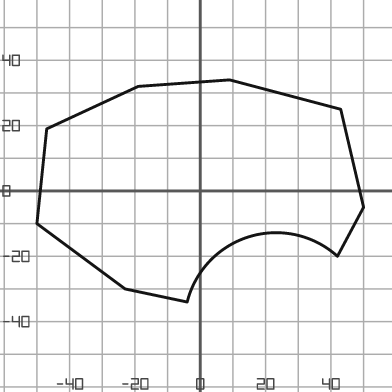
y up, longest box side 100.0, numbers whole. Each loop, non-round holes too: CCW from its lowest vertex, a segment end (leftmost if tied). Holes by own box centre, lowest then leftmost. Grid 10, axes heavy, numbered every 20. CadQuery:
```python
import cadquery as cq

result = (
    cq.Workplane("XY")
    .moveTo(-4.0, -34.0)
    .threePointArc((15.0, -14.0), (42.0, -20.0))
    .lineTo(50.0, -5.0)
    .lineTo(43.0, 25.0)
    .lineTo(9.0, 34.0)
    .lineTo(-19.0, 32.0)
    .lineTo(-47.0, 19.0)
    .lineTo(-50.0, -10.0)
    .lineTo(-23.0, -30.0)
    .close()
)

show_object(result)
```